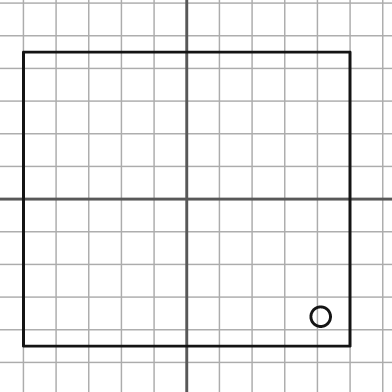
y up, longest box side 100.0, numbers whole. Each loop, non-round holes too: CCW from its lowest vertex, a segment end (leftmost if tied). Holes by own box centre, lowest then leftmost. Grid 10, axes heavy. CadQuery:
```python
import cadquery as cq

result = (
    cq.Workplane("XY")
    .moveTo(-50.0, -45.0)
    .lineTo(50.0, -45.0)
    .lineTo(50.0, 45.0)
    .lineTo(-50.0, 45.0)
    .close()
    .moveTo(41.0, -36.0)
    .circle(3.0)
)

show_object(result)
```